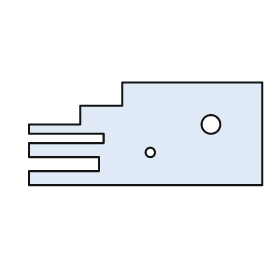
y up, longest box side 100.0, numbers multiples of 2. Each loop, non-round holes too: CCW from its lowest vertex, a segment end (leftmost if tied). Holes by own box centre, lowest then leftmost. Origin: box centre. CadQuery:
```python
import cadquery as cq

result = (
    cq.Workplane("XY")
    .moveTo(-50.0, -22.0)
    .lineTo(50.0, -22.0)
    .lineTo(50.0, 22.0)
    .lineTo(-10.0, 22.0)
    .lineTo(-10.0, 12.0)
    .lineTo(-28.0, 12.0)
    .lineTo(-28.0, 4.0)
    .lineTo(-50.0, 4.0)
    .lineTo(-50.0, 0.0)
    .lineTo(-18.0, 0.0)
    .lineTo(-18.0, -4.0)
    .lineTo(-50.0, -4.0)
    .lineTo(-50.0, -10.0)
    .lineTo(-20.0, -10.0)
    .lineTo(-20.0, -16.0)
    .lineTo(-50.0, -16.0)
    .close()
    .moveTo(2.0, -8.0)
    .circle(2.0)
    .moveTo(28.0, 4.0)
    .circle(4.0)
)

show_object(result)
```